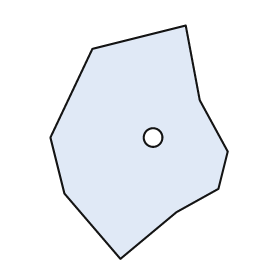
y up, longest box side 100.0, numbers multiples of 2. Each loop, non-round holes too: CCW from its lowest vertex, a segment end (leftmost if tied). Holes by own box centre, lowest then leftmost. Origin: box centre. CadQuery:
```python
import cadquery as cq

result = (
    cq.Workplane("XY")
    .moveTo(-8.0, -50.0)
    .lineTo(16.0, -30.0)
    .lineTo(34.0, -20.0)
    .lineTo(38.0, -4.0)
    .lineTo(26.0, 18.0)
    .lineTo(20.0, 50.0)
    .lineTo(-20.0, 40.0)
    .lineTo(-38.0, 2.0)
    .lineTo(-32.0, -22.0)
    .close()
    .moveTo(6.0, 2.0)
    .circle(4.0)
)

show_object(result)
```